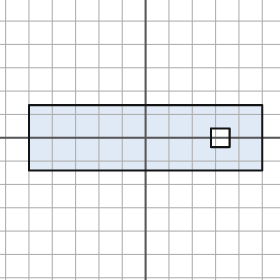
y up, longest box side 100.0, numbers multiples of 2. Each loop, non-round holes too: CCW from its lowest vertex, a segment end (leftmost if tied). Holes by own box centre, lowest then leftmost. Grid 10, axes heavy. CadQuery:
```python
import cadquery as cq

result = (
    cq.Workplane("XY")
    .moveTo(-50.0, -14.0)
    .lineTo(50.0, -14.0)
    .lineTo(50.0, 14.0)
    .lineTo(-50.0, 14.0)
    .close()
    .moveTo(28.0, -4.0)
    .lineTo(36.0, -4.0)
    .lineTo(36.0, 4.0)
    .lineTo(28.0, 4.0)
    .close()
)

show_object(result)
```